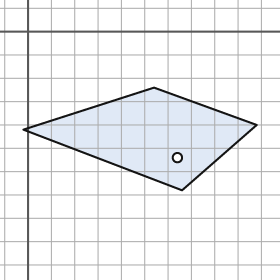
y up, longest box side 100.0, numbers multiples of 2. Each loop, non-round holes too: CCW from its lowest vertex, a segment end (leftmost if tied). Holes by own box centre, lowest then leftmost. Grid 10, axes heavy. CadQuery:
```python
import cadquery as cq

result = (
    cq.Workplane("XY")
    .moveTo(66.0, -68.0)
    .lineTo(98.0, -40.0)
    .lineTo(54.0, -24.0)
    .lineTo(-2.0, -42.0)
    .close()
    .moveTo(64.0, -54.0)
    .circle(2.0)
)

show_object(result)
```